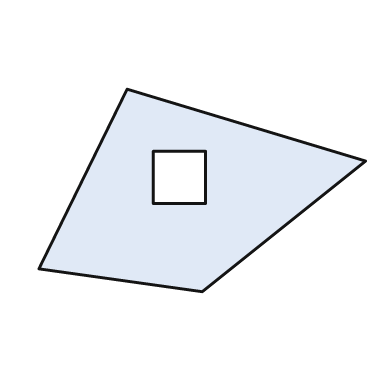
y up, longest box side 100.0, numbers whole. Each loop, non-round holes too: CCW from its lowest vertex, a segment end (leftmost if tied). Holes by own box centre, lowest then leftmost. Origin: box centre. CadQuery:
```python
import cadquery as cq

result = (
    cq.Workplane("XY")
    .moveTo(0.0, -31.0)
    .lineTo(50.0, 9.0)
    .lineTo(-23.0, 31.0)
    .lineTo(-50.0, -24.0)
    .close()
    .moveTo(-15.0, -4.0)
    .lineTo(1.0, -4.0)
    .lineTo(1.0, 12.0)
    .lineTo(-15.0, 12.0)
    .close()
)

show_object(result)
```